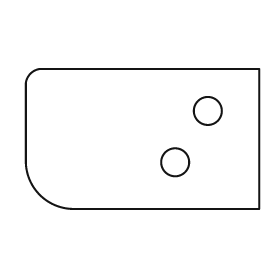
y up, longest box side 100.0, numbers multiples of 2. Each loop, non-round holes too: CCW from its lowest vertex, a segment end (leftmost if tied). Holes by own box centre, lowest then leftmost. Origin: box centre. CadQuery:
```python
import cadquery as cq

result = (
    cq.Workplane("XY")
    .moveTo(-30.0, -30.0)
    .lineTo(50.0, -30.0)
    .lineTo(50.0, 30.0)
    .lineTo(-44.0, 30.0)
    .threePointArc((-48.0, 28.0), (-50.0, 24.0))
    .lineTo(-50.0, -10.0)
    .threePointArc((-44.0, -24.0), (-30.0, -30.0))
    .close()
    .moveTo(14.0, -10.0)
    .circle(6.0)
    .moveTo(28.0, 12.0)
    .circle(6.0)
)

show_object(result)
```